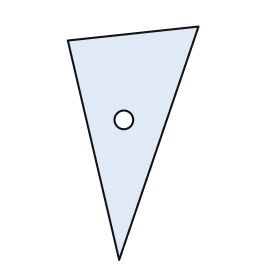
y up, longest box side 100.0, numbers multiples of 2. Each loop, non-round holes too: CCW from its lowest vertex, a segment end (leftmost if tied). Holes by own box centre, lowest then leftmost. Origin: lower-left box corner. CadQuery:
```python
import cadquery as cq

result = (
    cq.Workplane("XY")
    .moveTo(22.0, 0.0)
    .lineTo(56.0, 100.0)
    .lineTo(0.0, 94.0)
    .close()
    .moveTo(24.0, 60.0)
    .circle(4.0)
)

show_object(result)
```